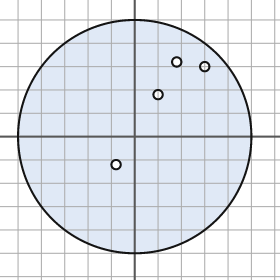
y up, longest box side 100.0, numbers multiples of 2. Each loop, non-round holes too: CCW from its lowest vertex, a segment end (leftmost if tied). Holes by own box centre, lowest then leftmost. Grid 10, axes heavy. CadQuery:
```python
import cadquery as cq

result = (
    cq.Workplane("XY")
    .moveTo(0.0, 0.0)
    .circle(50.0)
    .moveTo(-8.0, -12.0)
    .circle(2.0)
    .moveTo(10.0, 18.0)
    .circle(2.0)
    .moveTo(30.0, 30.0)
    .circle(2.0)
    .moveTo(18.0, 32.0)
    .circle(2.0)
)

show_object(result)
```